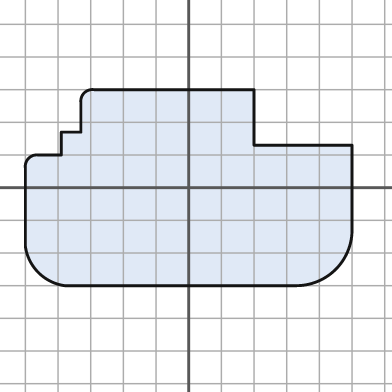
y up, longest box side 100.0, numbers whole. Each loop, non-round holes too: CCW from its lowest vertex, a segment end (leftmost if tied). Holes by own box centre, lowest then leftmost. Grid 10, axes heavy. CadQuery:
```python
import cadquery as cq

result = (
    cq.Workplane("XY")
    .moveTo(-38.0, -30.0)
    .lineTo(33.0, -30.0)
    .threePointArc((45.0, -25.0), (50.0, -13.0))
    .lineTo(50.0, 13.0)
    .lineTo(20.0, 13.0)
    .lineTo(20.0, 30.0)
    .lineTo(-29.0, 30.0)
    .threePointArc((-32.0, 29.0), (-33.0, 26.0))
    .lineTo(-33.0, 17.0)
    .lineTo(-39.0, 17.0)
    .lineTo(-39.0, 10.0)
    .lineTo(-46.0, 10.0)
    .threePointArc((-49.0, 9.0), (-50.0, 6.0))
    .lineTo(-50.0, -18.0)
    .threePointArc((-46.0, -26.0), (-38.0, -30.0))
    .close()
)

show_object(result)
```